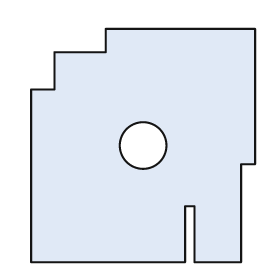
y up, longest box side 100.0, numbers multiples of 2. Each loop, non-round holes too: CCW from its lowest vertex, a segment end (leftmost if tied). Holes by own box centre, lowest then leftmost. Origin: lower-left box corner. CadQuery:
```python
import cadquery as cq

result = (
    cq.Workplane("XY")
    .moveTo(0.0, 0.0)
    .lineTo(66.0, 0.0)
    .lineTo(66.0, 24.0)
    .lineTo(70.0, 24.0)
    .lineTo(70.0, 0.0)
    .lineTo(90.0, 0.0)
    .lineTo(90.0, 42.0)
    .lineTo(96.0, 42.0)
    .lineTo(96.0, 100.0)
    .lineTo(32.0, 100.0)
    .lineTo(32.0, 90.0)
    .lineTo(10.0, 90.0)
    .lineTo(10.0, 74.0)
    .lineTo(0.0, 74.0)
    .close()
    .moveTo(48.0, 50.0)
    .circle(10.0)
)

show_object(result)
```